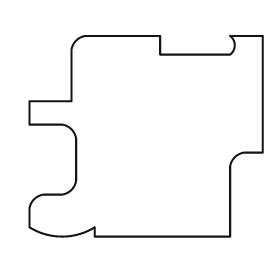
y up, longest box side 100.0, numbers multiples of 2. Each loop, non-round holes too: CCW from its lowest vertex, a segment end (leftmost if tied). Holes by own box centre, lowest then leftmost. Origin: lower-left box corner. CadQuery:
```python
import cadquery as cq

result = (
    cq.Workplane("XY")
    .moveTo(28.0, 0.0)
    .lineTo(86.0, 0.0)
    .lineTo(86.0, 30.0)
    .threePointArc((88.0, 34.0), (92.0, 36.0))
    .lineTo(100.0, 36.0)
    .lineTo(100.0, 86.0)
    .lineTo(86.0, 86.0)
    .threePointArc((88.0, 82.0), (86.0, 78.0))
    .lineTo(56.0, 78.0)
    .lineTo(56.0, 86.0)
    .lineTo(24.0, 86.0)
    .threePointArc((20.0, 84.0), (18.0, 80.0))
    .lineTo(18.0, 58.0)
    .lineTo(0.0, 58.0)
    .lineTo(0.0, 48.0)
    .lineTo(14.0, 48.0)
    .threePointArc((18.0, 46.0), (20.0, 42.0))
    .lineTo(20.0, 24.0)
    .threePointArc((18.0, 20.0), (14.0, 18.0))
    .lineTo(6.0, 18.0)
    .threePointArc((2.0, 16.0), (0.0, 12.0))
    .lineTo(0.0, 4.0)
    .threePointArc((14.0, 0.0), (28.0, 4.0))
    .close()
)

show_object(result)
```